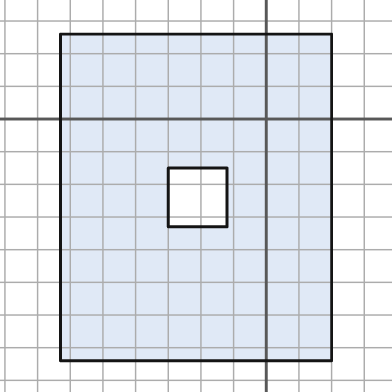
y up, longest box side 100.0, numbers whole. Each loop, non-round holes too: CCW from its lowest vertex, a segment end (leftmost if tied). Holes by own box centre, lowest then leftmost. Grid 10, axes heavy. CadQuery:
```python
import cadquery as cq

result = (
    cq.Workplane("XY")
    .moveTo(-63.0, -74.0)
    .lineTo(20.0, -74.0)
    .lineTo(20.0, 26.0)
    .lineTo(-63.0, 26.0)
    .close()
    .moveTo(-30.0, -33.0)
    .lineTo(-12.0, -33.0)
    .lineTo(-12.0, -15.0)
    .lineTo(-30.0, -15.0)
    .close()
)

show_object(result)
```